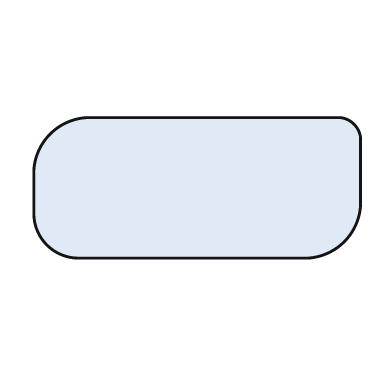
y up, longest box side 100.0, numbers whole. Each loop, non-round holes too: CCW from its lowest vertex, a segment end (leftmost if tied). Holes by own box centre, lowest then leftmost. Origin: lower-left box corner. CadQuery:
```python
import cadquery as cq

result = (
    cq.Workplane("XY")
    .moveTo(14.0, 0.0)
    .lineTo(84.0, 0.0)
    .threePointArc((95.0, 5.0), (100.0, 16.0))
    .lineTo(100.0, 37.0)
    .threePointArc((98.0, 41.0), (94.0, 43.0))
    .lineTo(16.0, 43.0)
    .threePointArc((5.0, 38.0), (0.0, 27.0))
    .lineTo(0.0, 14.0)
    .threePointArc((4.0, 4.0), (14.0, 0.0))
    .close()
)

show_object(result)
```